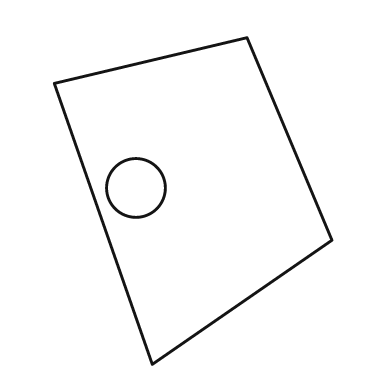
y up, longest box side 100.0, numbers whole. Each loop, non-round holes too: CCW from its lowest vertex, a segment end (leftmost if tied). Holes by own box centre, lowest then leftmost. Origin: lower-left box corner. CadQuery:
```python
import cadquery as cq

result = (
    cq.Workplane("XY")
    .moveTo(30.0, 0.0)
    .lineTo(85.0, 38.0)
    .lineTo(59.0, 100.0)
    .lineTo(0.0, 86.0)
    .close()
    .moveTo(25.0, 54.0)
    .circle(9.0)
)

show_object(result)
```